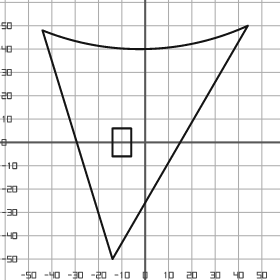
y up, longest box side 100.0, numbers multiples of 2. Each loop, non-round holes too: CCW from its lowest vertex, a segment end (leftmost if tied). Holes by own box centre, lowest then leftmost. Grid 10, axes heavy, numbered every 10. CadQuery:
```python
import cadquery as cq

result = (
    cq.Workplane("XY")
    .moveTo(-14.0, -50.0)
    .lineTo(44.0, 50.0)
    .threePointArc((0.0, 40.0), (-44.0, 48.0))
    .close()
    .moveTo(-14.0, -6.0)
    .lineTo(-6.0, -6.0)
    .lineTo(-6.0, 6.0)
    .lineTo(-14.0, 6.0)
    .close()
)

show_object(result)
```